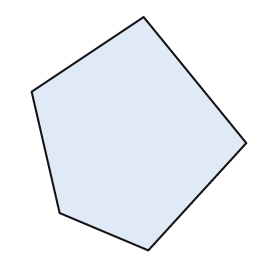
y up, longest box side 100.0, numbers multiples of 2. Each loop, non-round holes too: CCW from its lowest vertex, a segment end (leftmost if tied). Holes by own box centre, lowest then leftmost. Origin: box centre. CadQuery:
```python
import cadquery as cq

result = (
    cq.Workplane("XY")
    .moveTo(4.0, -50.0)
    .lineTo(46.0, -4.0)
    .lineTo(2.0, 50.0)
    .lineTo(-46.0, 18.0)
    .lineTo(-34.0, -34.0)
    .close()
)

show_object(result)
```